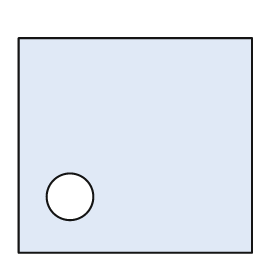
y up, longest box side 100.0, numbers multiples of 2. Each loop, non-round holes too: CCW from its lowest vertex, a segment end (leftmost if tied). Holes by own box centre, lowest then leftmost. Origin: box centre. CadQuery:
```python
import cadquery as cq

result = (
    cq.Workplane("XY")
    .moveTo(-50.0, -46.0)
    .lineTo(50.0, -46.0)
    .lineTo(50.0, 46.0)
    .lineTo(-50.0, 46.0)
    .close()
    .moveTo(-28.0, -22.0)
    .circle(10.0)
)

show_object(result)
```